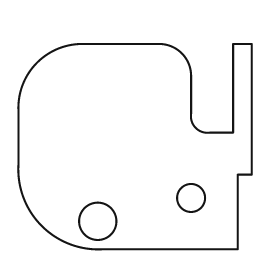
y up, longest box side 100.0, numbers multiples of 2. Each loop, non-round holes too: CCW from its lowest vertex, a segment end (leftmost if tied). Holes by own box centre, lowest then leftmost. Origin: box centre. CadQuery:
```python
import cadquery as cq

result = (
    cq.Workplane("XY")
    .moveTo(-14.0, -44.0)
    .lineTo(44.0, -44.0)
    .lineTo(44.0, -12.0)
    .lineTo(50.0, -12.0)
    .lineTo(50.0, 44.0)
    .lineTo(42.0, 44.0)
    .lineTo(42.0, 6.0)
    .lineTo(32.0, 6.0)
    .threePointArc((26.0, 8.0), (24.0, 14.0))
    .lineTo(24.0, 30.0)
    .threePointArc((20.0, 40.0), (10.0, 44.0))
    .lineTo(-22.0, 44.0)
    .threePointArc((-42.0, 36.0), (-50.0, 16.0))
    .lineTo(-50.0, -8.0)
    .threePointArc((-40.0, -34.0), (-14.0, -44.0))
    .close()
    .moveTo(-16.0, -32.0)
    .circle(8.0)
    .moveTo(24.0, -22.0)
    .circle(6.0)
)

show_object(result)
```